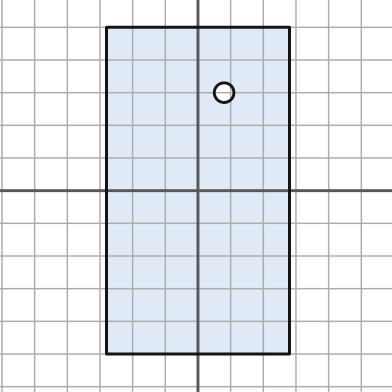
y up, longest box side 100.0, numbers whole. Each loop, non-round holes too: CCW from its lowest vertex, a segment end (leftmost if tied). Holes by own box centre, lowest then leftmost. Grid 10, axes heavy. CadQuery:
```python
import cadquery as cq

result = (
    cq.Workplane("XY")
    .moveTo(-28.0, -50.0)
    .lineTo(28.0, -50.0)
    .lineTo(28.0, 50.0)
    .lineTo(-28.0, 50.0)
    .close()
    .moveTo(8.0, 30.0)
    .circle(3.0)
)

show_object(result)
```